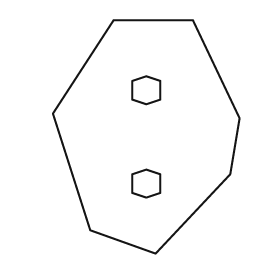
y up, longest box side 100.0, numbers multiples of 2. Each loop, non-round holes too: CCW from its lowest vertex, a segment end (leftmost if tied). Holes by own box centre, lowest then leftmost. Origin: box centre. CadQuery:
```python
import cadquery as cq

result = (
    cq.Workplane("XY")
    .moveTo(4.0, -50.0)
    .lineTo(36.0, -16.0)
    .lineTo(40.0, 8.0)
    .lineTo(20.0, 50.0)
    .lineTo(-14.0, 50.0)
    .lineTo(-40.0, 10.0)
    .lineTo(-24.0, -40.0)
    .close()
    .moveTo(0.0, -26.0)
    .lineTo(6.0, -24.0)
    .lineTo(6.0, -16.0)
    .lineTo(0.0, -14.0)
    .lineTo(-6.0, -16.0)
    .lineTo(-6.0, -24.0)
    .close()
    .moveTo(0.0, 14.0)
    .lineTo(6.0, 16.0)
    .lineTo(6.0, 24.0)
    .lineTo(0.0, 26.0)
    .lineTo(-6.0, 24.0)
    .lineTo(-6.0, 16.0)
    .close()
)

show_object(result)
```